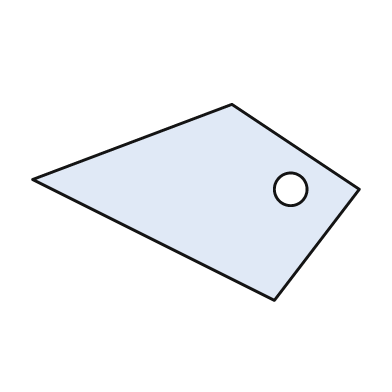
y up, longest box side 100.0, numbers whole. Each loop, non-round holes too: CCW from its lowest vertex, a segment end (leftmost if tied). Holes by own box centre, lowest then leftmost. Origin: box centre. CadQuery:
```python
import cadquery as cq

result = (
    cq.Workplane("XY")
    .moveTo(24.0, -30.0)
    .lineTo(50.0, 4.0)
    .lineTo(11.0, 30.0)
    .lineTo(-50.0, 7.0)
    .close()
    .moveTo(29.0, 4.0)
    .circle(5.0)
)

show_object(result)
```